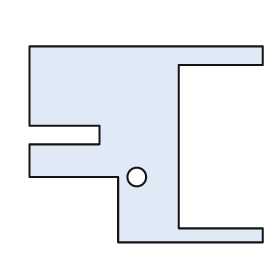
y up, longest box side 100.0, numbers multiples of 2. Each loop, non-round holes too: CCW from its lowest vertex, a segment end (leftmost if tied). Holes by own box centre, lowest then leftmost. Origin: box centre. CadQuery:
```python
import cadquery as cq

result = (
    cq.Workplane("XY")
    .moveTo(-12.0, -42.0)
    .lineTo(50.0, -42.0)
    .lineTo(50.0, -36.0)
    .lineTo(14.0, -36.0)
    .lineTo(14.0, 34.0)
    .lineTo(50.0, 34.0)
    .lineTo(50.0, 42.0)
    .lineTo(-50.0, 42.0)
    .lineTo(-50.0, 8.0)
    .lineTo(-20.0, 8.0)
    .lineTo(-20.0, 0.0)
    .lineTo(-50.0, 0.0)
    .lineTo(-50.0, -14.0)
    .lineTo(-12.0, -14.0)
    .close()
    .moveTo(-4.0, -14.0)
    .circle(4.0)
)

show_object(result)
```